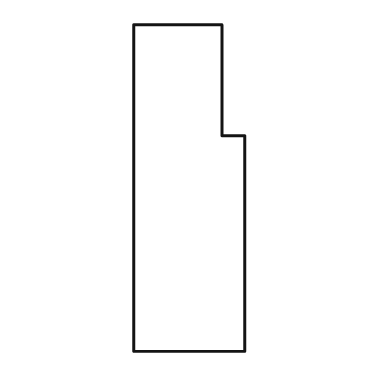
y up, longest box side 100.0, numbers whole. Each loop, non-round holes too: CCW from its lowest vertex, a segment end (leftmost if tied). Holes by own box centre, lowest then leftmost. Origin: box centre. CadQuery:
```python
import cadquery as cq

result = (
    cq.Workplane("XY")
    .moveTo(-17.0, -50.0)
    .lineTo(17.0, -50.0)
    .lineTo(17.0, 16.0)
    .lineTo(10.0, 16.0)
    .lineTo(10.0, 50.0)
    .lineTo(-17.0, 50.0)
    .close()
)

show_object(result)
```